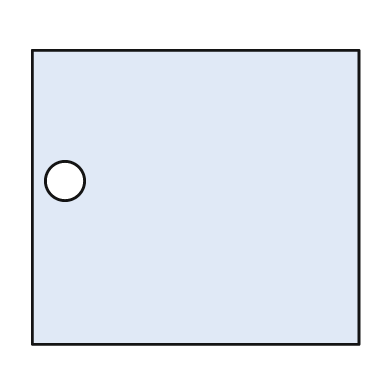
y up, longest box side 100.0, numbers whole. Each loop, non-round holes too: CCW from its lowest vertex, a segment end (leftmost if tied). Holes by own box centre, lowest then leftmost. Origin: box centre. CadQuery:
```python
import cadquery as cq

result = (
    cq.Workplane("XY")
    .moveTo(-50.0, -45.0)
    .lineTo(50.0, -45.0)
    .lineTo(50.0, 45.0)
    .lineTo(-50.0, 45.0)
    .close()
    .moveTo(-40.0, 5.0)
    .circle(6.0)
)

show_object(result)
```